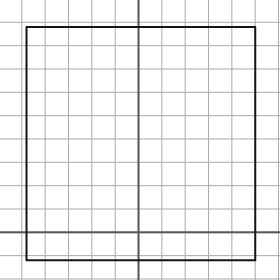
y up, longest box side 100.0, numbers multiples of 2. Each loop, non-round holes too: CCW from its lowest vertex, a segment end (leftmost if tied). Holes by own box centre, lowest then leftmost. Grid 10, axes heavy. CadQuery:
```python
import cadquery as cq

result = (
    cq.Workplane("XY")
    .moveTo(-48.0, -12.0)
    .lineTo(50.0, -12.0)
    .lineTo(50.0, 88.0)
    .lineTo(-48.0, 88.0)
    .close()
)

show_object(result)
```